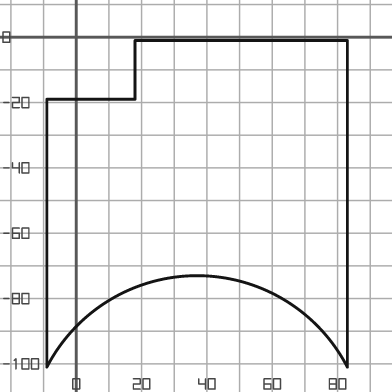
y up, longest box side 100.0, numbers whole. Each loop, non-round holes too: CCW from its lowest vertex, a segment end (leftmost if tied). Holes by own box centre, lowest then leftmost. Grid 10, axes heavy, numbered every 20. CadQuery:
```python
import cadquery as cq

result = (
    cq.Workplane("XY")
    .moveTo(-9.0, -101.0)
    .threePointArc((37.0, -73.0), (83.0, -101.0))
    .lineTo(83.0, -1.0)
    .lineTo(18.0, -1.0)
    .lineTo(18.0, -19.0)
    .lineTo(-9.0, -19.0)
    .close()
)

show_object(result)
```